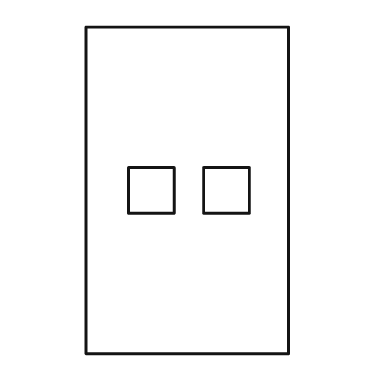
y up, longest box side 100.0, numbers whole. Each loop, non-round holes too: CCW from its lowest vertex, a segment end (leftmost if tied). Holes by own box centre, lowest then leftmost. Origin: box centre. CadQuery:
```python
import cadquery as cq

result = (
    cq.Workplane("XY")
    .moveTo(-31.0, -50.0)
    .lineTo(31.0, -50.0)
    .lineTo(31.0, 50.0)
    .lineTo(-31.0, 50.0)
    .close()
    .moveTo(-18.0, -7.0)
    .lineTo(-4.0, -7.0)
    .lineTo(-4.0, 7.0)
    .lineTo(-18.0, 7.0)
    .close()
    .moveTo(5.0, -7.0)
    .lineTo(19.0, -7.0)
    .lineTo(19.0, 7.0)
    .lineTo(5.0, 7.0)
    .close()
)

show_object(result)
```